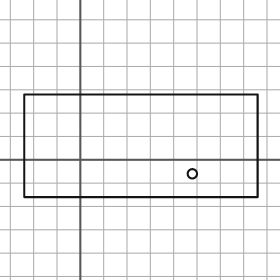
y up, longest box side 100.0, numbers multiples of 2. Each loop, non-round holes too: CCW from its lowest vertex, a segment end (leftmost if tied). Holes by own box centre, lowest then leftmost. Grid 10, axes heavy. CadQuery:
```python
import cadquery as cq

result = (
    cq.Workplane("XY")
    .moveTo(-24.0, -16.0)
    .lineTo(76.0, -16.0)
    .lineTo(76.0, 28.0)
    .lineTo(-24.0, 28.0)
    .close()
    .moveTo(48.0, -6.0)
    .circle(2.0)
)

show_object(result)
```